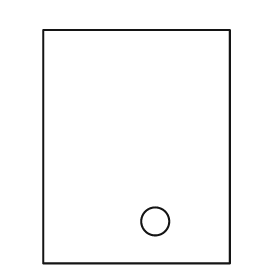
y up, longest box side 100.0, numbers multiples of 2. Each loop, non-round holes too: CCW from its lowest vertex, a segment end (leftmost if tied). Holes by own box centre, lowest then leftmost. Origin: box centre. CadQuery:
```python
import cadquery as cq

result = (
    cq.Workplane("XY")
    .moveTo(-40.0, -50.0)
    .lineTo(40.0, -50.0)
    .lineTo(40.0, 50.0)
    .lineTo(-40.0, 50.0)
    .close()
    .moveTo(8.0, -32.0)
    .circle(6.0)
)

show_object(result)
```